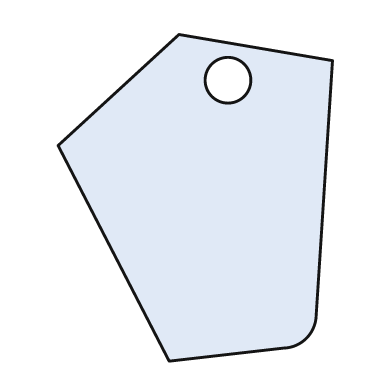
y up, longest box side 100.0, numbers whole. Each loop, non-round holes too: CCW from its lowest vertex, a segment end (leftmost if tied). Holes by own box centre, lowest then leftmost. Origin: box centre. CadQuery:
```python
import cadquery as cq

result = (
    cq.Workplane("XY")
    .moveTo(-8.0, -50.0)
    .lineTo(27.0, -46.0)
    .threePointArc((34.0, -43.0), (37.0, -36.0))
    .lineTo(42.0, 42.0)
    .lineTo(-5.0, 50.0)
    .lineTo(-42.0, 16.0)
    .close()
    .moveTo(10.0, 36.0)
    .circle(7.0)
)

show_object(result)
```